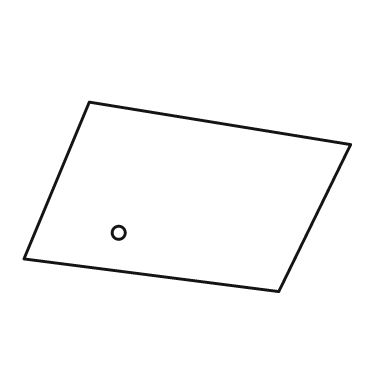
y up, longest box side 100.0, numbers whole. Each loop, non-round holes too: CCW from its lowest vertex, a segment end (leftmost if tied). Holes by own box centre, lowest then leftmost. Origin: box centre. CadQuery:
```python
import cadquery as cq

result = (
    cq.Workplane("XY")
    .moveTo(28.0, -29.0)
    .lineTo(50.0, 16.0)
    .lineTo(-30.0, 29.0)
    .lineTo(-50.0, -19.0)
    .close()
    .moveTo(-21.0, -11.0)
    .circle(2.0)
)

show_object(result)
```